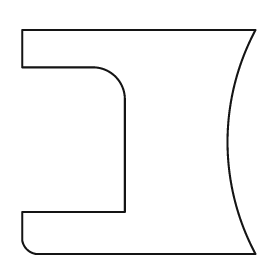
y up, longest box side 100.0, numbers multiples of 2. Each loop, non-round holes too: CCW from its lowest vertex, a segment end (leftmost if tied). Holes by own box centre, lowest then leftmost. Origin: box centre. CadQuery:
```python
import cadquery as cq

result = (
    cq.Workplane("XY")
    .moveTo(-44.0, -48.0)
    .lineTo(50.0, -48.0)
    .threePointArc((38.0, 0.0), (50.0, 48.0))
    .lineTo(-50.0, 48.0)
    .lineTo(-50.0, 32.0)
    .lineTo(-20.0, 32.0)
    .threePointArc((-10.0, 28.0), (-6.0, 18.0))
    .lineTo(-6.0, -30.0)
    .lineTo(-50.0, -30.0)
    .lineTo(-50.0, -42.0)
    .threePointArc((-48.0, -46.0), (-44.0, -48.0))
    .close()
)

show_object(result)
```